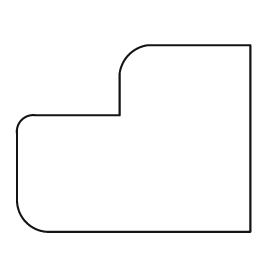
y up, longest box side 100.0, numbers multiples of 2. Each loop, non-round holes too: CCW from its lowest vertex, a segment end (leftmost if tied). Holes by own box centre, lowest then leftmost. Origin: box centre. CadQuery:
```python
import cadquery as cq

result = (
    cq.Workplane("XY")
    .moveTo(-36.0, -40.0)
    .lineTo(50.0, -40.0)
    .lineTo(50.0, 40.0)
    .lineTo(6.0, 40.0)
    .threePointArc((-2.0, 36.0), (-6.0, 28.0))
    .lineTo(-6.0, 10.0)
    .lineTo(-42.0, 10.0)
    .threePointArc((-48.0, 8.0), (-50.0, 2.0))
    .lineTo(-50.0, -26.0)
    .threePointArc((-46.0, -36.0), (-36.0, -40.0))
    .close()
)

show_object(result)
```